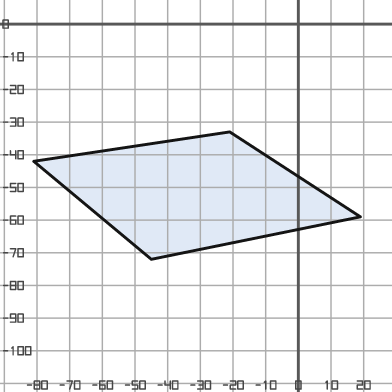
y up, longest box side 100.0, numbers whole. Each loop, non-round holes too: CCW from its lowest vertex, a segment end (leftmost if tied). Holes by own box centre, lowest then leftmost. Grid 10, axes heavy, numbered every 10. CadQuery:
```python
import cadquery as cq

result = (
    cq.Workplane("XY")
    .moveTo(-45.0, -72.0)
    .lineTo(19.0, -59.0)
    .lineTo(-21.0, -33.0)
    .lineTo(-81.0, -42.0)
    .close()
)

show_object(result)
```